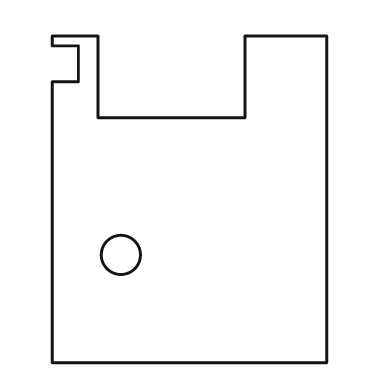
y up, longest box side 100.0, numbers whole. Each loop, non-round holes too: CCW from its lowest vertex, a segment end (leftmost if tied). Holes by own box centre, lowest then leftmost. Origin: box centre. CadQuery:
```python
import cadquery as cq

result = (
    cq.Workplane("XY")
    .moveTo(-42.0, -50.0)
    .lineTo(42.0, -50.0)
    .lineTo(42.0, 50.0)
    .lineTo(17.0, 50.0)
    .lineTo(17.0, 25.0)
    .lineTo(-28.0, 25.0)
    .lineTo(-28.0, 50.0)
    .lineTo(-42.0, 50.0)
    .lineTo(-42.0, 47.0)
    .lineTo(-34.0, 47.0)
    .lineTo(-34.0, 36.0)
    .lineTo(-42.0, 36.0)
    .close()
    .moveTo(-21.0, -17.0)
    .circle(6.0)
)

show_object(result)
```